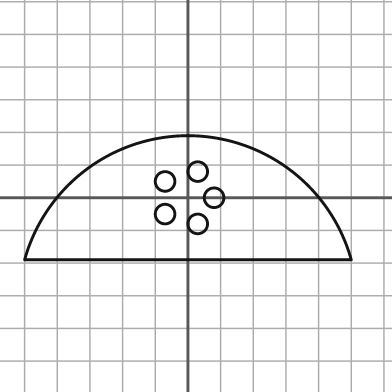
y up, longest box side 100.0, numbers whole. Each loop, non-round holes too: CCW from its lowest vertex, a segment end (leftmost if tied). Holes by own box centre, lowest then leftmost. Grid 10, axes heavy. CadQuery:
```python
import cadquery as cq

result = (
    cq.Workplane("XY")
    .moveTo(-50.0, -19.0)
    .lineTo(50.0, -19.0)
    .threePointArc((0.0, 19.0), (-50.0, -19.0))
    .close()
    .moveTo(3.0, -8.0)
    .circle(3.0)
    .moveTo(-7.0, -5.0)
    .circle(3.0)
    .moveTo(8.0, 0.0)
    .circle(3.0)
    .moveTo(-7.0, 5.0)
    .circle(3.0)
    .moveTo(3.0, 8.0)
    .circle(3.0)
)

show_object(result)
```